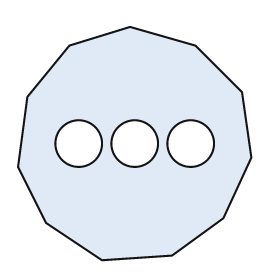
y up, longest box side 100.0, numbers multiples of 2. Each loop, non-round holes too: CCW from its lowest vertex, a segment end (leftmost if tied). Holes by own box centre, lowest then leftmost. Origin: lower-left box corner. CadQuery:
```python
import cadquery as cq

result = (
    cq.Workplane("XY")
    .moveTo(36.0, 0.0)
    .lineTo(66.0, 2.0)
    .lineTo(88.0, 18.0)
    .lineTo(100.0, 44.0)
    .lineTo(96.0, 72.0)
    .lineTo(76.0, 92.0)
    .lineTo(48.0, 100.0)
    .lineTo(22.0, 92.0)
    .lineTo(4.0, 70.0)
    .lineTo(0.0, 40.0)
    .lineTo(12.0, 16.0)
    .close()
    .moveTo(26.0, 50.0)
    .circle(10.0)
    .moveTo(50.0, 50.0)
    .circle(10.0)
    .moveTo(74.0, 50.0)
    .circle(10.0)
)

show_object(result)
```